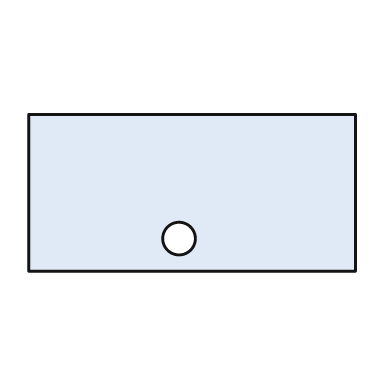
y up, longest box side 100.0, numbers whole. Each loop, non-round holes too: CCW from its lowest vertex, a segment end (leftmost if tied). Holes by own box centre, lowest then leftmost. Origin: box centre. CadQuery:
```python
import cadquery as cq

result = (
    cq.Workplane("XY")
    .moveTo(-50.0, -24.0)
    .lineTo(50.0, -24.0)
    .lineTo(50.0, 24.0)
    .lineTo(-50.0, 24.0)
    .close()
    .moveTo(-4.0, -14.0)
    .circle(5.0)
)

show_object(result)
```